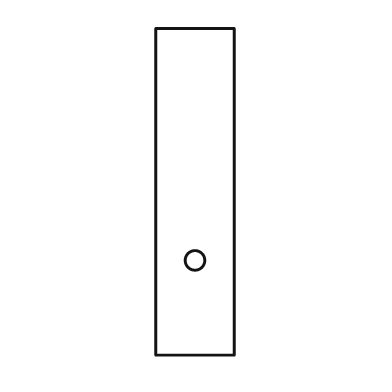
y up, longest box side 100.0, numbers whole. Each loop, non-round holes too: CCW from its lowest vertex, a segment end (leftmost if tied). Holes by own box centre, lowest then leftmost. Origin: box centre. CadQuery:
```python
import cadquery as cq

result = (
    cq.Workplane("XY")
    .moveTo(-12.0, -50.0)
    .lineTo(12.0, -50.0)
    .lineTo(12.0, 50.0)
    .lineTo(-12.0, 50.0)
    .close()
    .moveTo(0.0, -21.0)
    .circle(3.0)
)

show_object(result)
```